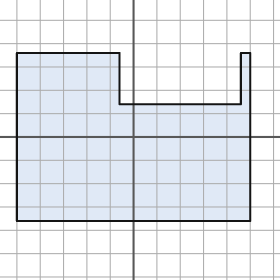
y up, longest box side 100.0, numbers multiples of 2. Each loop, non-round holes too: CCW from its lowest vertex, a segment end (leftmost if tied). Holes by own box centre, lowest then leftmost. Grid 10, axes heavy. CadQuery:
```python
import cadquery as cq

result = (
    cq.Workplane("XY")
    .moveTo(-50.0, -36.0)
    .lineTo(50.0, -36.0)
    .lineTo(50.0, 36.0)
    .lineTo(46.0, 36.0)
    .lineTo(46.0, 14.0)
    .lineTo(-6.0, 14.0)
    .lineTo(-6.0, 36.0)
    .lineTo(-50.0, 36.0)
    .close()
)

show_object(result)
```